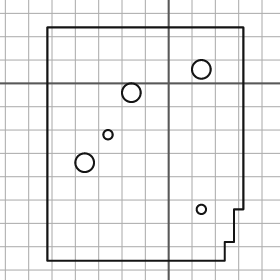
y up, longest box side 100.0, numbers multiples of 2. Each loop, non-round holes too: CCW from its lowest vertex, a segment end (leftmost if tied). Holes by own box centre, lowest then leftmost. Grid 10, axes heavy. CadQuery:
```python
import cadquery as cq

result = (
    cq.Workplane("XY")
    .moveTo(-52.0, -76.0)
    .lineTo(24.0, -76.0)
    .lineTo(24.0, -68.0)
    .lineTo(28.0, -68.0)
    .lineTo(28.0, -54.0)
    .lineTo(32.0, -54.0)
    .lineTo(32.0, 24.0)
    .lineTo(-52.0, 24.0)
    .close()
    .moveTo(14.0, -54.0)
    .circle(2.0)
    .moveTo(-36.0, -34.0)
    .circle(4.0)
    .moveTo(-26.0, -22.0)
    .circle(2.0)
    .moveTo(-16.0, -4.0)
    .circle(4.0)
    .moveTo(14.0, 6.0)
    .circle(4.0)
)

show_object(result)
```